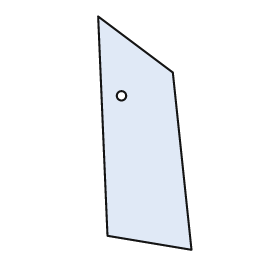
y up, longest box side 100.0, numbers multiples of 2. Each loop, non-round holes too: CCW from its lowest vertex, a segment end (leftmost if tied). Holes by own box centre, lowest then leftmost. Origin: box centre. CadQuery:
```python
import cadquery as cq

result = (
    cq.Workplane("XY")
    .moveTo(20.0, -50.0)
    .lineTo(12.0, 26.0)
    .lineTo(-20.0, 50.0)
    .lineTo(-16.0, -44.0)
    .close()
    .moveTo(-10.0, 16.0)
    .circle(2.0)
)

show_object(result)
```